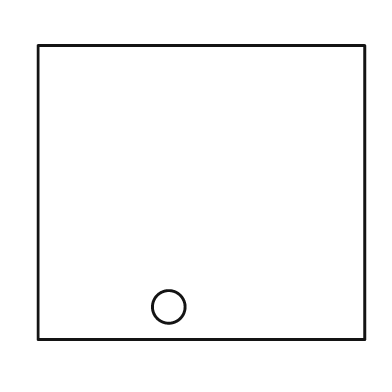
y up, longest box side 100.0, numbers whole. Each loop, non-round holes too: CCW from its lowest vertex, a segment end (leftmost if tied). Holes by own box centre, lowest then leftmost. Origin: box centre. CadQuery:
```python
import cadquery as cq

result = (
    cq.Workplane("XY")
    .moveTo(-50.0, -45.0)
    .lineTo(50.0, -45.0)
    .lineTo(50.0, 45.0)
    .lineTo(-50.0, 45.0)
    .close()
    .moveTo(-10.0, -35.0)
    .circle(5.0)
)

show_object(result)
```